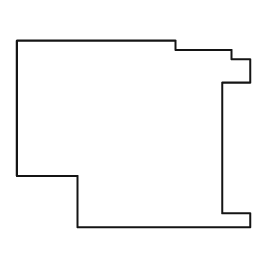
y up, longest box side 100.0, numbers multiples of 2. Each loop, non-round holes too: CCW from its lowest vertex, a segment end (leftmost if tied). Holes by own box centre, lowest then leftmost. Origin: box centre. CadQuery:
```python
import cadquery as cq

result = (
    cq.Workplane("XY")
    .moveTo(-24.0, -40.0)
    .lineTo(50.0, -40.0)
    .lineTo(50.0, -34.0)
    .lineTo(38.0, -34.0)
    .lineTo(38.0, 22.0)
    .lineTo(50.0, 22.0)
    .lineTo(50.0, 32.0)
    .lineTo(42.0, 32.0)
    .lineTo(42.0, 36.0)
    .lineTo(18.0, 36.0)
    .lineTo(18.0, 40.0)
    .lineTo(-50.0, 40.0)
    .lineTo(-50.0, -18.0)
    .lineTo(-24.0, -18.0)
    .close()
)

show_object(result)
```